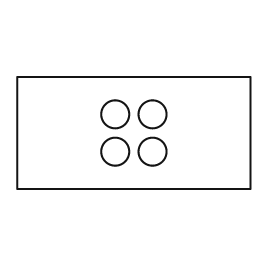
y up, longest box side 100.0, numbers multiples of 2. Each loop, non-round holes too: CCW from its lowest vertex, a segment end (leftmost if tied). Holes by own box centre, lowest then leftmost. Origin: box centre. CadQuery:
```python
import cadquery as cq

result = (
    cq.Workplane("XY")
    .moveTo(-50.0, -24.0)
    .lineTo(50.0, -24.0)
    .lineTo(50.0, 24.0)
    .lineTo(-50.0, 24.0)
    .close()
    .moveTo(-8.0, -8.0)
    .circle(6.0)
    .moveTo(8.0, -8.0)
    .circle(6.0)
    .moveTo(-8.0, 8.0)
    .circle(6.0)
    .moveTo(8.0, 8.0)
    .circle(6.0)
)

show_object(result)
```